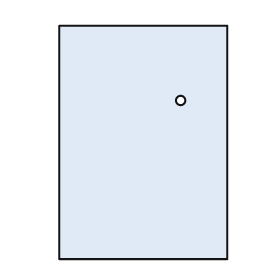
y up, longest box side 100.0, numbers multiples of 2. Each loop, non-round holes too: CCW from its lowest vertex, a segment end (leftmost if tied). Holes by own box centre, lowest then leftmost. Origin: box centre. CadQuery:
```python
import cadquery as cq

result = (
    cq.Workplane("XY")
    .moveTo(-36.0, -50.0)
    .lineTo(36.0, -50.0)
    .lineTo(36.0, 50.0)
    .lineTo(-36.0, 50.0)
    .close()
    .moveTo(16.0, 18.0)
    .circle(2.0)
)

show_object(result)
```